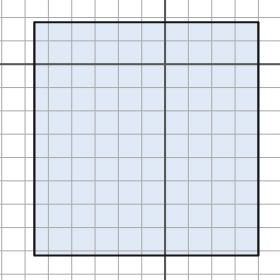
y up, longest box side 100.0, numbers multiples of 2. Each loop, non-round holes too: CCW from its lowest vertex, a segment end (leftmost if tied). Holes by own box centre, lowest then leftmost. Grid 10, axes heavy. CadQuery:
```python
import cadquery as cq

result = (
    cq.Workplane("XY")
    .moveTo(-56.0, -82.0)
    .lineTo(40.0, -82.0)
    .lineTo(40.0, 18.0)
    .lineTo(-56.0, 18.0)
    .close()
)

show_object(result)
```